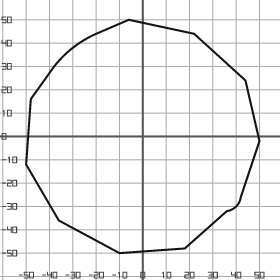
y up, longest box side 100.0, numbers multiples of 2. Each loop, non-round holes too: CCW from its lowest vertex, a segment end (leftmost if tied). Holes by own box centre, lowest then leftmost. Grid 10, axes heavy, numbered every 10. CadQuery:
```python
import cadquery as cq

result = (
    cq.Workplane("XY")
    .moveTo(-10.0, -50.0)
    .lineTo(18.0, -48.0)
    .lineTo(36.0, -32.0)
    .threePointArc((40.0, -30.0), (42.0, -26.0))
    .lineTo(50.0, -2.0)
    .lineTo(44.0, 24.0)
    .lineTo(22.0, 44.0)
    .lineTo(-6.0, 50.0)
    .lineTo(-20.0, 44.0)
    .threePointArc((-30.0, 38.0), (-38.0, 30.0))
    .lineTo(-48.0, 16.0)
    .lineTo(-50.0, -12.0)
    .lineTo(-36.0, -36.0)
    .close()
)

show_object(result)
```